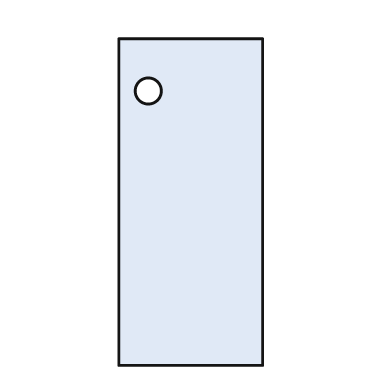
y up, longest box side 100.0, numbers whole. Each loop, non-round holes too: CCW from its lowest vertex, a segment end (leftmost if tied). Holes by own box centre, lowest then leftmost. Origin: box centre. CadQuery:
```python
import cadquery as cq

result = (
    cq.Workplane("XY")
    .moveTo(-22.0, -50.0)
    .lineTo(22.0, -50.0)
    .lineTo(22.0, 50.0)
    .lineTo(-22.0, 50.0)
    .close()
    .moveTo(-13.0, 34.0)
    .circle(4.0)
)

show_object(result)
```